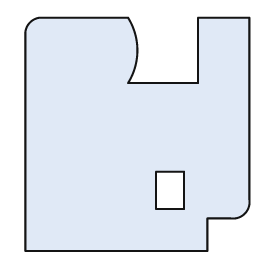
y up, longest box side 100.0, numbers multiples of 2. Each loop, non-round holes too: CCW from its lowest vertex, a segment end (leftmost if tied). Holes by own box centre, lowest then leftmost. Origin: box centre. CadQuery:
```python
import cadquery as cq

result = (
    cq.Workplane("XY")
    .moveTo(-48.0, -50.0)
    .lineTo(30.0, -50.0)
    .lineTo(30.0, -36.0)
    .lineTo(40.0, -36.0)
    .threePointArc((46.0, -34.0), (48.0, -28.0))
    .lineTo(48.0, 50.0)
    .lineTo(26.0, 50.0)
    .lineTo(26.0, 22.0)
    .lineTo(-4.0, 22.0)
    .threePointArc((0.0, 36.0), (-4.0, 50.0))
    .lineTo(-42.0, 50.0)
    .threePointArc((-46.0, 48.0), (-48.0, 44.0))
    .close()
    .moveTo(8.0, -32.0)
    .lineTo(20.0, -32.0)
    .lineTo(20.0, -16.0)
    .lineTo(8.0, -16.0)
    .close()
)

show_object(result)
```